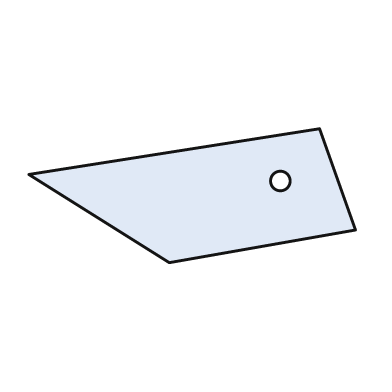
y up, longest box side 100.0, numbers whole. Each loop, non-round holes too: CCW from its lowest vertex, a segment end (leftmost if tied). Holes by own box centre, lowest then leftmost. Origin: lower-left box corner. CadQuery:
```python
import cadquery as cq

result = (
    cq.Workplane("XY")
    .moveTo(43.0, 0.0)
    .lineTo(100.0, 10.0)
    .lineTo(89.0, 41.0)
    .lineTo(0.0, 27.0)
    .close()
    .moveTo(77.0, 25.0)
    .circle(3.0)
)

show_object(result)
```